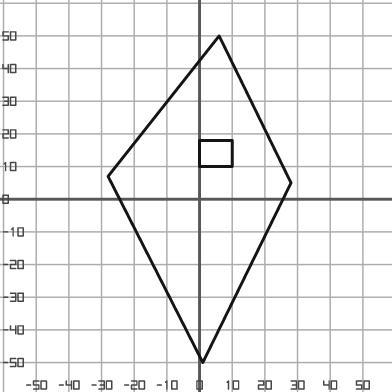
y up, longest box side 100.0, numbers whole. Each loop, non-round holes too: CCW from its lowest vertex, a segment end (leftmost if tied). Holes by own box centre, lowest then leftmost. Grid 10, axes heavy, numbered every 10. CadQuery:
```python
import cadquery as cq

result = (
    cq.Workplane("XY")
    .moveTo(1.0, -50.0)
    .lineTo(28.0, 5.0)
    .lineTo(6.0, 50.0)
    .lineTo(-28.0, 7.0)
    .close()
    .moveTo(0.0, 10.0)
    .lineTo(10.0, 10.0)
    .lineTo(10.0, 18.0)
    .lineTo(0.0, 18.0)
    .close()
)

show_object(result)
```